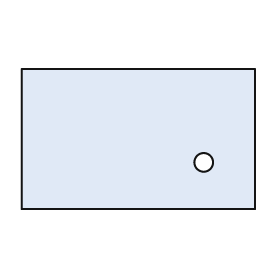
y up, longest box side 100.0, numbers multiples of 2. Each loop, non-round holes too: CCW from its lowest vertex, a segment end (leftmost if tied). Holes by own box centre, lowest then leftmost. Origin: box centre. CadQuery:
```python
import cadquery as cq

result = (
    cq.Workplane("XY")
    .moveTo(-50.0, -30.0)
    .lineTo(50.0, -30.0)
    .lineTo(50.0, 30.0)
    .lineTo(-50.0, 30.0)
    .close()
    .moveTo(28.0, -10.0)
    .circle(4.0)
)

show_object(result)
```